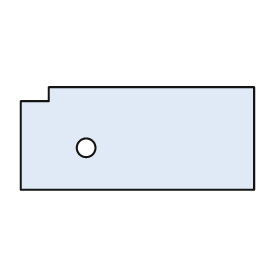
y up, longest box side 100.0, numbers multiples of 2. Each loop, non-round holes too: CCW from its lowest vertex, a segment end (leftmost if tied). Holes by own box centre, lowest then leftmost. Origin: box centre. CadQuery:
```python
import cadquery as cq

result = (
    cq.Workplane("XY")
    .moveTo(-50.0, -22.0)
    .lineTo(50.0, -22.0)
    .lineTo(50.0, 22.0)
    .lineTo(-38.0, 22.0)
    .lineTo(-38.0, 16.0)
    .lineTo(-50.0, 16.0)
    .close()
    .moveTo(-22.0, -4.0)
    .circle(4.0)
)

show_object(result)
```